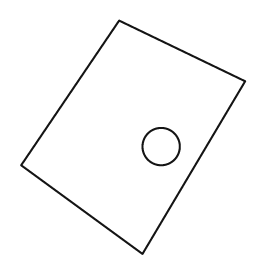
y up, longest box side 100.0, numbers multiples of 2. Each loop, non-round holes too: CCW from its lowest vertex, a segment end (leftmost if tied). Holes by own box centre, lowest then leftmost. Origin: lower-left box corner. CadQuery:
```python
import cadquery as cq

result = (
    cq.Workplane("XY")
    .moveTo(52.0, 0.0)
    .lineTo(96.0, 74.0)
    .lineTo(42.0, 100.0)
    .lineTo(0.0, 38.0)
    .close()
    .moveTo(60.0, 46.0)
    .circle(8.0)
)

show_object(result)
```